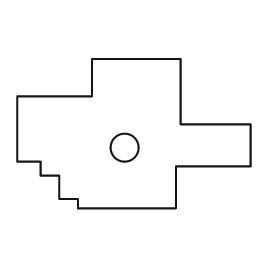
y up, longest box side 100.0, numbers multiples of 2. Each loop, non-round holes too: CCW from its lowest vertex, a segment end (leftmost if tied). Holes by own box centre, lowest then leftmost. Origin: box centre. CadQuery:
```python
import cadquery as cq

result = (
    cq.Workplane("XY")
    .moveTo(-24.0, -32.0)
    .lineTo(18.0, -32.0)
    .lineTo(18.0, -14.0)
    .lineTo(50.0, -14.0)
    .lineTo(50.0, 4.0)
    .lineTo(20.0, 4.0)
    .lineTo(20.0, 32.0)
    .lineTo(-18.0, 32.0)
    .lineTo(-18.0, 16.0)
    .lineTo(-50.0, 16.0)
    .lineTo(-50.0, -12.0)
    .lineTo(-40.0, -12.0)
    .lineTo(-40.0, -18.0)
    .lineTo(-32.0, -18.0)
    .lineTo(-32.0, -28.0)
    .lineTo(-24.0, -28.0)
    .close()
    .moveTo(-4.0, -6.0)
    .circle(6.0)
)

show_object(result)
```